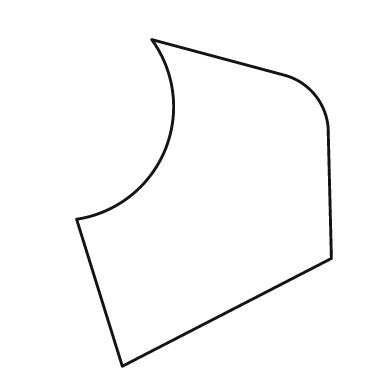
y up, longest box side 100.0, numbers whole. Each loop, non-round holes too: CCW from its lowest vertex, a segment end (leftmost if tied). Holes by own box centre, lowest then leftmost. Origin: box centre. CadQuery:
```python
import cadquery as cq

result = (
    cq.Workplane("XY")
    .moveTo(-25.0, -50.0)
    .lineTo(39.0, -17.0)
    .lineTo(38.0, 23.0)
    .threePointArc((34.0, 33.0), (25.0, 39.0))
    .lineTo(-16.0, 50.0)
    .threePointArc((-12.0, 16.0), (-39.0, -5.0))
    .close()
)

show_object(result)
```